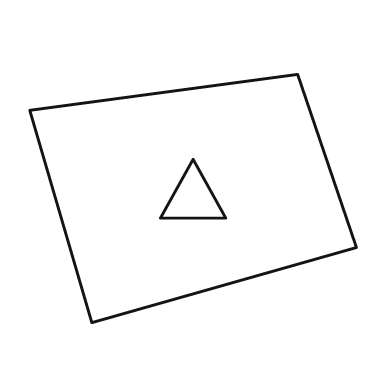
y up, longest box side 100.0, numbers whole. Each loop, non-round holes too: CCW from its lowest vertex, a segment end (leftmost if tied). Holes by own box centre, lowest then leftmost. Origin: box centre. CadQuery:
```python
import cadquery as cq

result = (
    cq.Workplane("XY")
    .moveTo(-31.0, -38.0)
    .lineTo(50.0, -15.0)
    .lineTo(32.0, 38.0)
    .lineTo(-50.0, 27.0)
    .close()
    .moveTo(-10.0, -6.0)
    .lineTo(10.0, -6.0)
    .lineTo(0.0, 12.0)
    .close()
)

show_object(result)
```